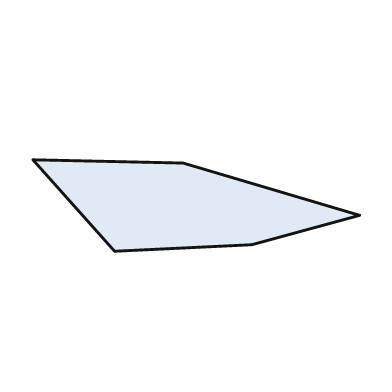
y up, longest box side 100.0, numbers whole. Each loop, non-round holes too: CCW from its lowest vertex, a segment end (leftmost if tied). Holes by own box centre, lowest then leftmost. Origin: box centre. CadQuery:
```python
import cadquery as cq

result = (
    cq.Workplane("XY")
    .moveTo(-25.0, -14.0)
    .lineTo(17.0, -12.0)
    .lineTo(50.0, -3.0)
    .lineTo(-4.0, 13.0)
    .lineTo(-50.0, 14.0)
    .close()
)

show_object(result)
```